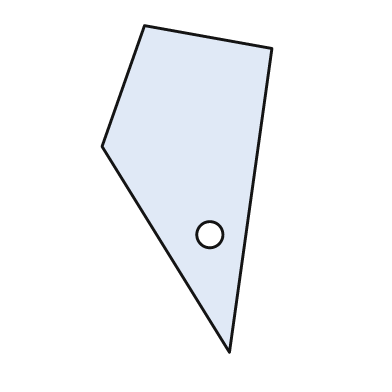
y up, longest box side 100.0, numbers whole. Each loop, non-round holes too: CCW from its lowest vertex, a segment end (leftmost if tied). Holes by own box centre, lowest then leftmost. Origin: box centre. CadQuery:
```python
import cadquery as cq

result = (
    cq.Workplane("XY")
    .moveTo(13.0, -50.0)
    .lineTo(26.0, 43.0)
    .lineTo(-13.0, 50.0)
    .lineTo(-26.0, 13.0)
    .close()
    .moveTo(7.0, -14.0)
    .circle(4.0)
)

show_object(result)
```